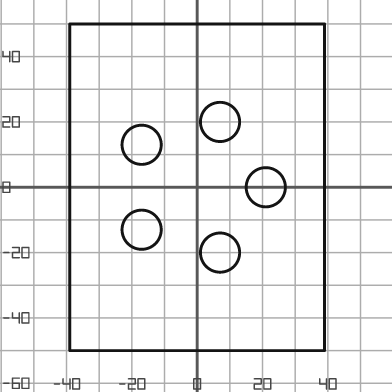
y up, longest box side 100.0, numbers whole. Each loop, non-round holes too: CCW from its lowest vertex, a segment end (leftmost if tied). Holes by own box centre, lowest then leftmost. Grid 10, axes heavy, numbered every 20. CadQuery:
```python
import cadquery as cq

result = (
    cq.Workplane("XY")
    .moveTo(-39.0, -50.0)
    .lineTo(39.0, -50.0)
    .lineTo(39.0, 50.0)
    .lineTo(-39.0, 50.0)
    .close()
    .moveTo(7.0, -20.0)
    .circle(6.0)
    .moveTo(-17.0, -13.0)
    .circle(6.0)
    .moveTo(21.0, 0.0)
    .circle(6.0)
    .moveTo(-17.0, 13.0)
    .circle(6.0)
    .moveTo(7.0, 20.0)
    .circle(6.0)
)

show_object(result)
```